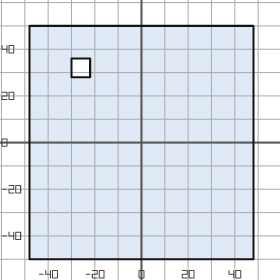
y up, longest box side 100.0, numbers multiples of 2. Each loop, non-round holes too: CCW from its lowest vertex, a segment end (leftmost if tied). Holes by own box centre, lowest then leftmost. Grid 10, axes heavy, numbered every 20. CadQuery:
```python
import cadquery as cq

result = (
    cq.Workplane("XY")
    .moveTo(-48.0, -50.0)
    .lineTo(48.0, -50.0)
    .lineTo(48.0, 50.0)
    .lineTo(-48.0, 50.0)
    .close()
    .moveTo(-30.0, 28.0)
    .lineTo(-22.0, 28.0)
    .lineTo(-22.0, 36.0)
    .lineTo(-30.0, 36.0)
    .close()
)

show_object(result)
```